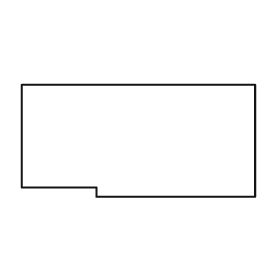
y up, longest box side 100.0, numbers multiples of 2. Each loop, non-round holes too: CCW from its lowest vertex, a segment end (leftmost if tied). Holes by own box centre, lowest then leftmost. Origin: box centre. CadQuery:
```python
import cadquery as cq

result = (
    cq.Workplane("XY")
    .moveTo(-18.0, -24.0)
    .lineTo(50.0, -24.0)
    .lineTo(50.0, 24.0)
    .lineTo(-50.0, 24.0)
    .lineTo(-50.0, -20.0)
    .lineTo(-18.0, -20.0)
    .close()
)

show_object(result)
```